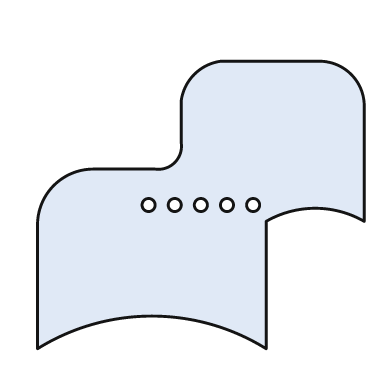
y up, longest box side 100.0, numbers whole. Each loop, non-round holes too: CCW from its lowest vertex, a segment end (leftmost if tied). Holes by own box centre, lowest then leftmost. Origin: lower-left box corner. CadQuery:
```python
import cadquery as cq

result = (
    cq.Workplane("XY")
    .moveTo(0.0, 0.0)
    .threePointArc((35.0, 10.0), (70.0, 0.0))
    .lineTo(70.0, 39.0)
    .threePointArc((85.0, 43.0), (100.0, 39.0))
    .lineTo(100.0, 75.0)
    .threePointArc((96.0, 84.0), (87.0, 88.0))
    .lineTo(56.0, 88.0)
    .threePointArc((48.0, 84.0), (44.0, 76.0))
    .lineTo(44.0, 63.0)
    .threePointArc((42.0, 57.0), (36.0, 55.0))
    .lineTo(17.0, 55.0)
    .threePointArc((5.0, 50.0), (0.0, 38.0))
    .close()
    .moveTo(34.0, 44.0)
    .circle(2.0)
    .moveTo(42.0, 44.0)
    .circle(2.0)
    .moveTo(50.0, 44.0)
    .circle(2.0)
    .moveTo(58.0, 44.0)
    .circle(2.0)
    .moveTo(66.0, 44.0)
    .circle(2.0)
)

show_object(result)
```